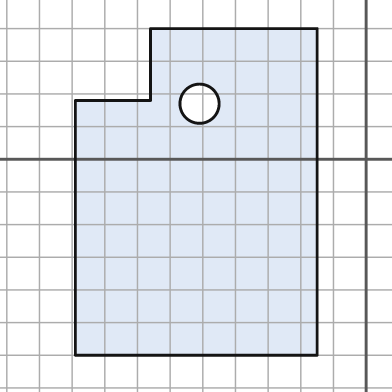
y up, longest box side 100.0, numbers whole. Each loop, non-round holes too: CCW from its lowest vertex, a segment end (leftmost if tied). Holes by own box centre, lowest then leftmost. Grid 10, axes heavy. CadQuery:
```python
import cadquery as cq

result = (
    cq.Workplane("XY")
    .moveTo(-89.0, -60.0)
    .lineTo(-15.0, -60.0)
    .lineTo(-15.0, 40.0)
    .lineTo(-66.0, 40.0)
    .lineTo(-66.0, 18.0)
    .lineTo(-89.0, 18.0)
    .close()
    .moveTo(-51.0, 17.0)
    .circle(6.0)
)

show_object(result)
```